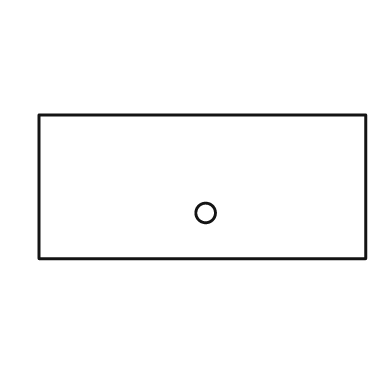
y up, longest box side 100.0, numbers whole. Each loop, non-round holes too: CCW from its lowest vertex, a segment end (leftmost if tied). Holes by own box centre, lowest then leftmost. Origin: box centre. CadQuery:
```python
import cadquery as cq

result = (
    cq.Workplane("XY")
    .moveTo(-50.0, -22.0)
    .lineTo(50.0, -22.0)
    .lineTo(50.0, 22.0)
    .lineTo(-50.0, 22.0)
    .close()
    .moveTo(1.0, -8.0)
    .circle(3.0)
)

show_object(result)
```